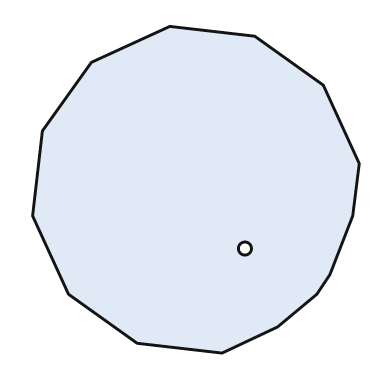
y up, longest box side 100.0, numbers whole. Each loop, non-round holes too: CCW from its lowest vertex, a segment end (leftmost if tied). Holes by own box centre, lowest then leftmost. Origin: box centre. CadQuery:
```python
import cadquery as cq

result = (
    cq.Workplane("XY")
    .moveTo(8.0, -50.0)
    .lineTo(25.0, -42.0)
    .lineTo(37.0, -32.0)
    .lineTo(41.0, -26.0)
    .lineTo(48.0, -8.0)
    .lineTo(50.0, 8.0)
    .lineTo(39.0, 32.0)
    .lineTo(18.0, 47.0)
    .lineTo(-8.0, 50.0)
    .lineTo(-32.0, 39.0)
    .lineTo(-47.0, 18.0)
    .lineTo(-50.0, -8.0)
    .lineTo(-39.0, -32.0)
    .lineTo(-18.0, -47.0)
    .close()
    .moveTo(15.0, -18.0)
    .circle(2.0)
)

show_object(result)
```